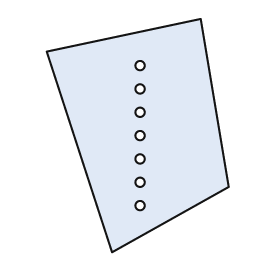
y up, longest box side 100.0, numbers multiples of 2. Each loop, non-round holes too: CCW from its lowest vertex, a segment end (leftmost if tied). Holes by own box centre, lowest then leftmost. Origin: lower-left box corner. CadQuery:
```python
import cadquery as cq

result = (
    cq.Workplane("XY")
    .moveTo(28.0, 0.0)
    .lineTo(78.0, 28.0)
    .lineTo(66.0, 100.0)
    .lineTo(0.0, 86.0)
    .close()
    .moveTo(40.0, 20.0)
    .circle(2.0)
    .moveTo(40.0, 30.0)
    .circle(2.0)
    .moveTo(40.0, 40.0)
    .circle(2.0)
    .moveTo(40.0, 50.0)
    .circle(2.0)
    .moveTo(40.0, 60.0)
    .circle(2.0)
    .moveTo(40.0, 70.0)
    .circle(2.0)
    .moveTo(40.0, 80.0)
    .circle(2.0)
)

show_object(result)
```